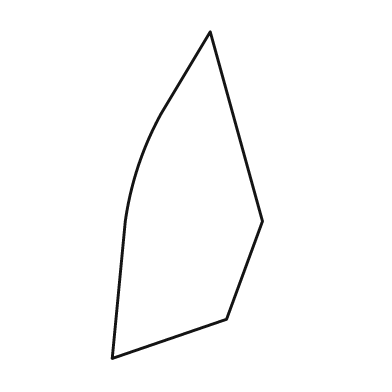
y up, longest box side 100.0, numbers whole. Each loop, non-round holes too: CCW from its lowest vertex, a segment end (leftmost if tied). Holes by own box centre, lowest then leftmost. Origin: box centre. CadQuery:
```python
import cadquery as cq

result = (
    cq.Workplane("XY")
    .moveTo(-23.0, -50.0)
    .lineTo(12.0, -38.0)
    .lineTo(23.0, -8.0)
    .lineTo(7.0, 50.0)
    .lineTo(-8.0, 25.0)
    .threePointArc((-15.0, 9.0), (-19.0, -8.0))
    .close()
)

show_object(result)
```